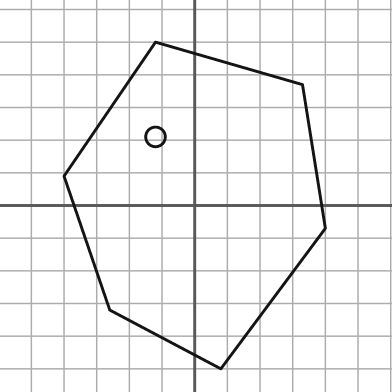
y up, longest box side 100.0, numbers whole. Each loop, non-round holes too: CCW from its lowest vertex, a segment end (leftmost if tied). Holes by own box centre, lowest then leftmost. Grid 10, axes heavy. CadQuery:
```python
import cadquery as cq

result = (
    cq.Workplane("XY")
    .moveTo(8.0, -50.0)
    .lineTo(40.0, -7.0)
    .lineTo(33.0, 37.0)
    .lineTo(-12.0, 50.0)
    .lineTo(-40.0, 9.0)
    .lineTo(-26.0, -32.0)
    .close()
    .moveTo(-12.0, 21.0)
    .circle(3.0)
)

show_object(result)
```